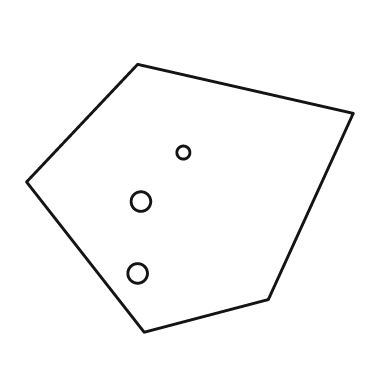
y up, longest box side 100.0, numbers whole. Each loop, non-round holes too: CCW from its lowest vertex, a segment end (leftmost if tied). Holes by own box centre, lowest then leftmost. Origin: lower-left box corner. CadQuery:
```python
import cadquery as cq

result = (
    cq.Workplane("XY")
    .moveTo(36.0, 0.0)
    .lineTo(74.0, 10.0)
    .lineTo(100.0, 67.0)
    .lineTo(34.0, 82.0)
    .lineTo(0.0, 46.0)
    .close()
    .moveTo(34.0, 18.0)
    .circle(3.0)
    .moveTo(35.0, 40.0)
    .circle(3.0)
    .moveTo(48.0, 55.0)
    .circle(2.0)
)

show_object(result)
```